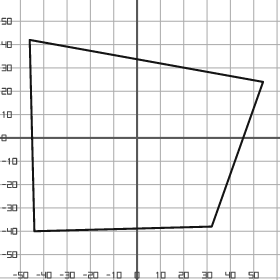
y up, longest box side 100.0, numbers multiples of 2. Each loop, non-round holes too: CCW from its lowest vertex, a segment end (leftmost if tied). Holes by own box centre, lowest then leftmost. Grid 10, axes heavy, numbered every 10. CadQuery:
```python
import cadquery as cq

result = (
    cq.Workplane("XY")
    .moveTo(-44.0, -40.0)
    .lineTo(32.0, -38.0)
    .lineTo(54.0, 24.0)
    .lineTo(-46.0, 42.0)
    .close()
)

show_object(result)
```